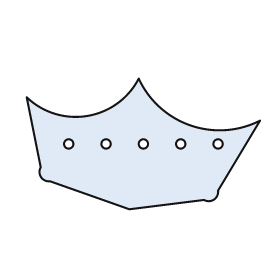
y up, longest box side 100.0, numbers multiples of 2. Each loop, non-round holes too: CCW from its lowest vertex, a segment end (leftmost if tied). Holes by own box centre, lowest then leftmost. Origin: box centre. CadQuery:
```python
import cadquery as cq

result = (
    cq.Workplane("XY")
    .moveTo(-6.0, -28.0)
    .lineTo(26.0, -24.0)
    .threePointArc((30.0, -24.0), (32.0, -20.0))
    .lineTo(50.0, 10.0)
    .threePointArc((20.0, 8.0), (-2.0, 28.0))
    .threePointArc((-24.0, 12.0), (-50.0, 20.0))
    .lineTo(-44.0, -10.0)
    .threePointArc((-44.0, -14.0), (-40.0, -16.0))
    .close()
    .moveTo(-32.0, 0.0)
    .circle(2.0)
    .moveTo(-16.0, 0.0)
    .circle(2.0)
    .moveTo(0.0, 0.0)
    .circle(2.0)
    .moveTo(16.0, 0.0)
    .circle(2.0)
    .moveTo(32.0, 0.0)
    .circle(2.0)
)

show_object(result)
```